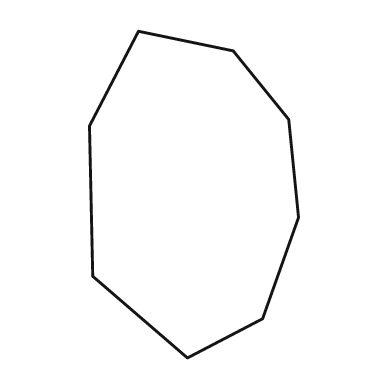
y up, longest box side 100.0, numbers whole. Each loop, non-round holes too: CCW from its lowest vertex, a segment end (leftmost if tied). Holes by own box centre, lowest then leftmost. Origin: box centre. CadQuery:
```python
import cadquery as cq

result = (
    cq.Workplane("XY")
    .moveTo(-2.0, -50.0)
    .lineTo(21.0, -38.0)
    .lineTo(32.0, -7.0)
    .lineTo(29.0, 23.0)
    .lineTo(12.0, 44.0)
    .lineTo(-17.0, 50.0)
    .lineTo(-32.0, 21.0)
    .lineTo(-31.0, -25.0)
    .close()
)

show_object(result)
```